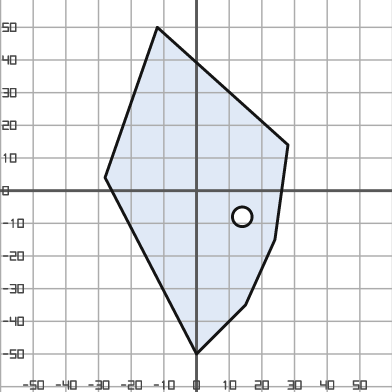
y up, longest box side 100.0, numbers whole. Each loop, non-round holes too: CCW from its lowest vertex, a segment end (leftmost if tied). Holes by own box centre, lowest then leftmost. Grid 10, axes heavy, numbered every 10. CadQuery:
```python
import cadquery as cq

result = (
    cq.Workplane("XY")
    .moveTo(0.0, -50.0)
    .lineTo(15.0, -35.0)
    .lineTo(24.0, -15.0)
    .lineTo(28.0, 14.0)
    .lineTo(-12.0, 50.0)
    .lineTo(-28.0, 4.0)
    .close()
    .moveTo(14.0, -8.0)
    .circle(3.0)
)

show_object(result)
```